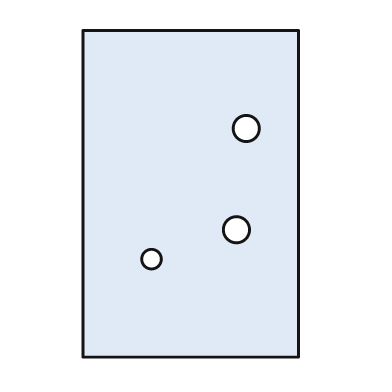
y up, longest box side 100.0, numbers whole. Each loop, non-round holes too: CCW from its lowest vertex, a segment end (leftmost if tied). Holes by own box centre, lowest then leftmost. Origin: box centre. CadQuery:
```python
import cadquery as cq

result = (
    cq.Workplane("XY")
    .moveTo(-33.0, -50.0)
    .lineTo(33.0, -50.0)
    .lineTo(33.0, 50.0)
    .lineTo(-33.0, 50.0)
    .close()
    .moveTo(-12.0, -20.0)
    .circle(3.0)
    .moveTo(14.0, -11.0)
    .circle(4.0)
    .moveTo(17.0, 20.0)
    .circle(4.0)
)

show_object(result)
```